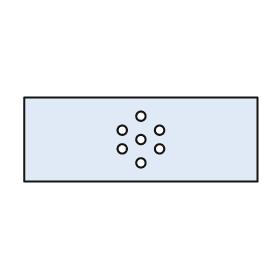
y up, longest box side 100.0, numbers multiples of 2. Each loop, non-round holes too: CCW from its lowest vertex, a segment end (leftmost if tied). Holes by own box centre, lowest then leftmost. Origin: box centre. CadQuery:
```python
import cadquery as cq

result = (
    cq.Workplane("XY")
    .moveTo(-50.0, -18.0)
    .lineTo(50.0, -18.0)
    .lineTo(50.0, 18.0)
    .lineTo(-50.0, 18.0)
    .close()
    .moveTo(0.0, -10.0)
    .circle(2.0)
    .moveTo(-8.0, -4.0)
    .circle(2.0)
    .moveTo(8.0, -4.0)
    .circle(2.0)
    .moveTo(0.0, 0.0)
    .circle(2.0)
    .moveTo(-8.0, 4.0)
    .circle(2.0)
    .moveTo(8.0, 4.0)
    .circle(2.0)
    .moveTo(0.0, 10.0)
    .circle(2.0)
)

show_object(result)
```